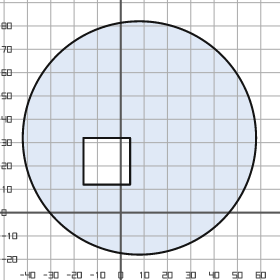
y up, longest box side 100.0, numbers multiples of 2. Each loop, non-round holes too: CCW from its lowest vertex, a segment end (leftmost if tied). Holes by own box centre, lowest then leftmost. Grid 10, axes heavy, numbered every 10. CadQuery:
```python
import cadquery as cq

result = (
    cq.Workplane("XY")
    .moveTo(8.0, 32.0)
    .circle(50.0)
    .moveTo(-16.0, 12.0)
    .lineTo(4.0, 12.0)
    .lineTo(4.0, 32.0)
    .lineTo(-16.0, 32.0)
    .close()
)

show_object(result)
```